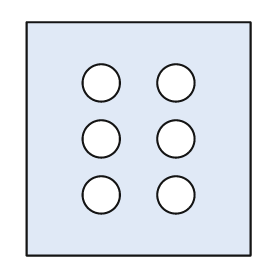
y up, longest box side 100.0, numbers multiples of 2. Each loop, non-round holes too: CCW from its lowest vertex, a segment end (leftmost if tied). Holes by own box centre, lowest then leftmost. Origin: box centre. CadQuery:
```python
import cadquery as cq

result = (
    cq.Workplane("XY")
    .moveTo(-48.0, -50.0)
    .lineTo(48.0, -50.0)
    .lineTo(48.0, 50.0)
    .lineTo(-48.0, 50.0)
    .close()
    .moveTo(-16.0, -24.0)
    .circle(8.0)
    .moveTo(16.0, -24.0)
    .circle(8.0)
    .moveTo(-16.0, 0.0)
    .circle(8.0)
    .moveTo(16.0, 0.0)
    .circle(8.0)
    .moveTo(-16.0, 24.0)
    .circle(8.0)
    .moveTo(16.0, 24.0)
    .circle(8.0)
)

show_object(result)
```